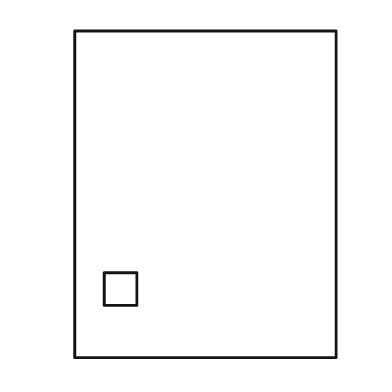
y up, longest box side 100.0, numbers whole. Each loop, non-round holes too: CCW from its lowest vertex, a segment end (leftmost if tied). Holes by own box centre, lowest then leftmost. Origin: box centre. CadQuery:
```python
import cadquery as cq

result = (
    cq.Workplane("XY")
    .moveTo(-40.0, -50.0)
    .lineTo(40.0, -50.0)
    .lineTo(40.0, 50.0)
    .lineTo(-40.0, 50.0)
    .close()
    .moveTo(-31.0, -34.0)
    .lineTo(-21.0, -34.0)
    .lineTo(-21.0, -24.0)
    .lineTo(-31.0, -24.0)
    .close()
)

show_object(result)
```